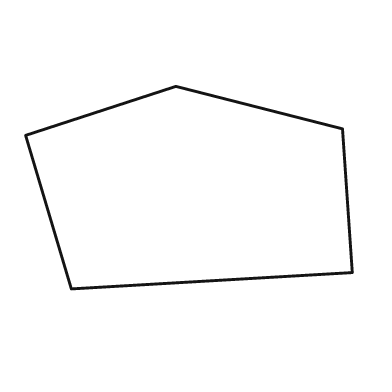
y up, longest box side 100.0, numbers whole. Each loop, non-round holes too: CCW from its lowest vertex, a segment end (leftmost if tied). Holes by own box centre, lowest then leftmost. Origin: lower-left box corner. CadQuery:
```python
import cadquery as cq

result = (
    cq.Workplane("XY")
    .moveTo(14.0, 0.0)
    .lineTo(100.0, 5.0)
    .lineTo(97.0, 49.0)
    .lineTo(46.0, 62.0)
    .lineTo(0.0, 47.0)
    .close()
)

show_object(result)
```